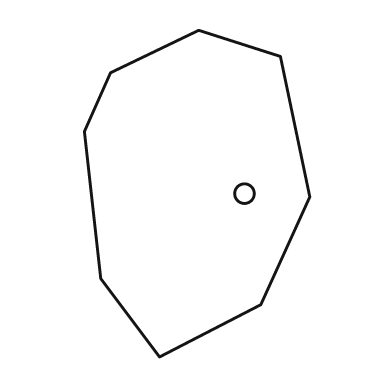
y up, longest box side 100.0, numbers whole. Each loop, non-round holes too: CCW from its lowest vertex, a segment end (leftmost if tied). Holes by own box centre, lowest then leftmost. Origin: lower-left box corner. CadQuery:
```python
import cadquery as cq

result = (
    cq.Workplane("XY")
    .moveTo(23.0, 0.0)
    .lineTo(54.0, 16.0)
    .lineTo(69.0, 49.0)
    .lineTo(60.0, 92.0)
    .lineTo(35.0, 100.0)
    .lineTo(8.0, 87.0)
    .lineTo(0.0, 69.0)
    .lineTo(5.0, 24.0)
    .close()
    .moveTo(49.0, 50.0)
    .circle(3.0)
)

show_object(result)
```